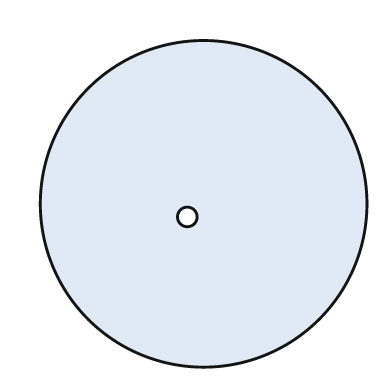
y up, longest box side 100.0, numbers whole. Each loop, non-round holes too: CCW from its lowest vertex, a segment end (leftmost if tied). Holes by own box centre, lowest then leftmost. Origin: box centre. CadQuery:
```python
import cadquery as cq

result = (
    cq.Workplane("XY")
    .moveTo(0.0, 0.0)
    .circle(50.0)
    .moveTo(-5.0, -4.0)
    .circle(3.0)
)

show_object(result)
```